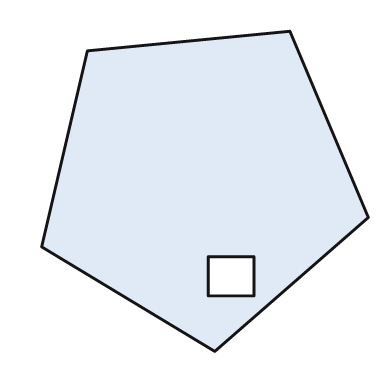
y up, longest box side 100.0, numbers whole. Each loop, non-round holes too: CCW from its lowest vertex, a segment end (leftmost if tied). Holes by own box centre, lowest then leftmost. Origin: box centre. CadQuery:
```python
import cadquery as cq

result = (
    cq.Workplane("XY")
    .moveTo(3.0, -49.0)
    .lineTo(50.0, -8.0)
    .lineTo(26.0, 49.0)
    .lineTo(-36.0, 43.0)
    .lineTo(-50.0, -17.0)
    .close()
    .moveTo(1.0, -32.0)
    .lineTo(15.0, -32.0)
    .lineTo(15.0, -20.0)
    .lineTo(1.0, -20.0)
    .close()
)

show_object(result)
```